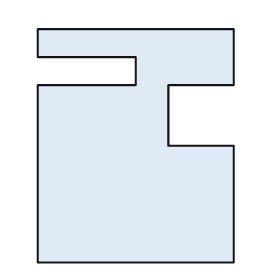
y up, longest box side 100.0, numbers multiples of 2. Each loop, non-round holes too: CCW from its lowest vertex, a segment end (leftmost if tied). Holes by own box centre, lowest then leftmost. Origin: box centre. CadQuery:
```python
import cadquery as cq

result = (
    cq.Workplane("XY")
    .moveTo(-42.0, -50.0)
    .lineTo(42.0, -50.0)
    .lineTo(42.0, 0.0)
    .lineTo(14.0, 0.0)
    .lineTo(14.0, 26.0)
    .lineTo(42.0, 26.0)
    .lineTo(42.0, 50.0)
    .lineTo(-42.0, 50.0)
    .lineTo(-42.0, 38.0)
    .lineTo(0.0, 38.0)
    .lineTo(0.0, 26.0)
    .lineTo(-42.0, 26.0)
    .close()
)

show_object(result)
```